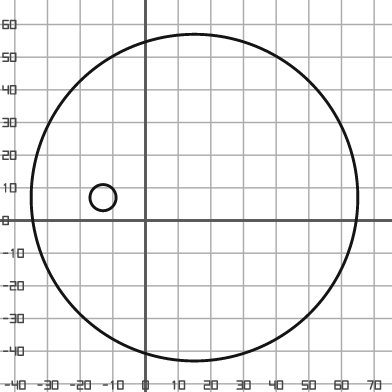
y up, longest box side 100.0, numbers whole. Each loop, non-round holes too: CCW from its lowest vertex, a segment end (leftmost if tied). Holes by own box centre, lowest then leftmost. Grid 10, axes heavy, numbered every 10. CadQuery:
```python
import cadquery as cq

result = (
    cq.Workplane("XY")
    .moveTo(15.0, 7.0)
    .circle(50.0)
    .moveTo(-13.0, 7.0)
    .circle(4.0)
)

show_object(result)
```